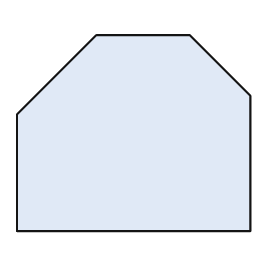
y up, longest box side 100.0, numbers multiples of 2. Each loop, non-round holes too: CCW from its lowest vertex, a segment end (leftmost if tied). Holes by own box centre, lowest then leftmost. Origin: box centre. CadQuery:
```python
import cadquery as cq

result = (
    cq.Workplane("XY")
    .moveTo(-50.0, -42.0)
    .lineTo(50.0, -42.0)
    .lineTo(50.0, 16.0)
    .lineTo(24.0, 42.0)
    .lineTo(-16.0, 42.0)
    .lineTo(-50.0, 8.0)
    .close()
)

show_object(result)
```